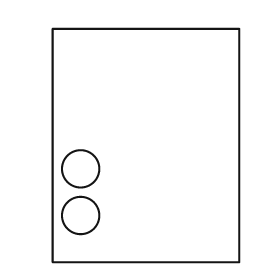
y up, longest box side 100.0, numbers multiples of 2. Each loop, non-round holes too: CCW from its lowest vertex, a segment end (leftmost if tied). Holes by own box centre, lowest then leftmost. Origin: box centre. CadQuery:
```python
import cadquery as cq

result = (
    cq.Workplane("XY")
    .moveTo(-40.0, -50.0)
    .lineTo(40.0, -50.0)
    .lineTo(40.0, 50.0)
    .lineTo(-40.0, 50.0)
    .close()
    .moveTo(-28.0, -30.0)
    .circle(8.0)
    .moveTo(-28.0, -10.0)
    .circle(8.0)
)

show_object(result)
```